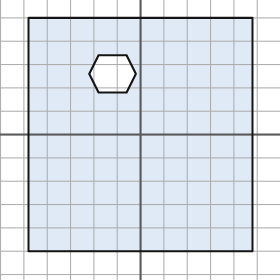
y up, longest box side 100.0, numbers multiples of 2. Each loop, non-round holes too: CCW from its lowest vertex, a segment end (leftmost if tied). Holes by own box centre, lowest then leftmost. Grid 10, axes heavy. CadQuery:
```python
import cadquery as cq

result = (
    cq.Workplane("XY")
    .moveTo(-48.0, -50.0)
    .lineTo(48.0, -50.0)
    .lineTo(48.0, 50.0)
    .lineTo(-48.0, 50.0)
    .close()
    .moveTo(-18.0, 18.0)
    .lineTo(-6.0, 18.0)
    .lineTo(-2.0, 26.0)
    .lineTo(-6.0, 34.0)
    .lineTo(-18.0, 34.0)
    .lineTo(-22.0, 26.0)
    .close()
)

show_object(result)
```